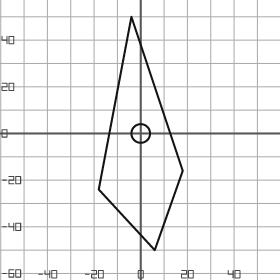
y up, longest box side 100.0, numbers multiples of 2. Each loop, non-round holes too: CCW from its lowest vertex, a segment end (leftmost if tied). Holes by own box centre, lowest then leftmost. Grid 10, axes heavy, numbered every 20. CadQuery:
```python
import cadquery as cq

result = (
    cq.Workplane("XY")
    .moveTo(6.0, -50.0)
    .lineTo(18.0, -16.0)
    .lineTo(-4.0, 50.0)
    .lineTo(-18.0, -24.0)
    .close()
    .moveTo(0.0, 0.0)
    .circle(4.0)
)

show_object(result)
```